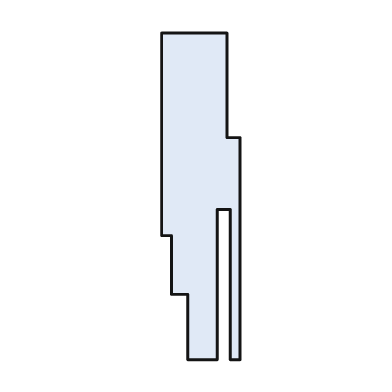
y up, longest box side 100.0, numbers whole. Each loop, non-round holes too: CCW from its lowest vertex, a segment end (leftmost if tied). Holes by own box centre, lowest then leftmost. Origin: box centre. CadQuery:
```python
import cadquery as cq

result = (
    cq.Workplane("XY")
    .moveTo(-4.0, -50.0)
    .lineTo(5.0, -50.0)
    .lineTo(5.0, -4.0)
    .lineTo(9.0, -4.0)
    .lineTo(9.0, -50.0)
    .lineTo(12.0, -50.0)
    .lineTo(12.0, 18.0)
    .lineTo(8.0, 18.0)
    .lineTo(8.0, 50.0)
    .lineTo(-12.0, 50.0)
    .lineTo(-12.0, -12.0)
    .lineTo(-9.0, -12.0)
    .lineTo(-9.0, -30.0)
    .lineTo(-4.0, -30.0)
    .close()
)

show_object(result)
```